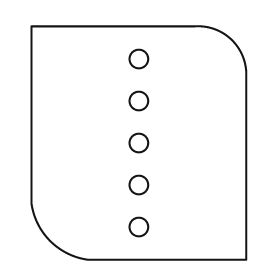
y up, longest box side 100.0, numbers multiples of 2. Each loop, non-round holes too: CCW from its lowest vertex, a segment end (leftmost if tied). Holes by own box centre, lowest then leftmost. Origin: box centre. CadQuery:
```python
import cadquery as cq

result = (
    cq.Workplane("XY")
    .moveTo(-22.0, -50.0)
    .lineTo(46.0, -50.0)
    .lineTo(46.0, 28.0)
    .threePointArc((40.0, 44.0), (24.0, 50.0))
    .lineTo(-46.0, 50.0)
    .lineTo(-46.0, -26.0)
    .threePointArc((-38.0, -42.0), (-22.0, -50.0))
    .close()
    .moveTo(0.0, -36.0)
    .circle(4.0)
    .moveTo(0.0, -18.0)
    .circle(4.0)
    .moveTo(0.0, 0.0)
    .circle(4.0)
    .moveTo(0.0, 18.0)
    .circle(4.0)
    .moveTo(0.0, 36.0)
    .circle(4.0)
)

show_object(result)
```